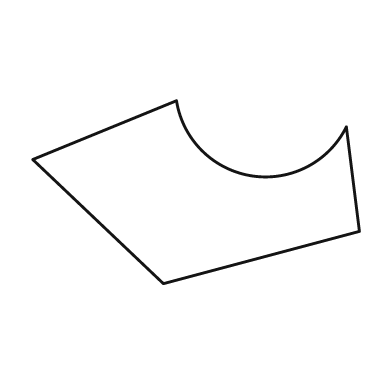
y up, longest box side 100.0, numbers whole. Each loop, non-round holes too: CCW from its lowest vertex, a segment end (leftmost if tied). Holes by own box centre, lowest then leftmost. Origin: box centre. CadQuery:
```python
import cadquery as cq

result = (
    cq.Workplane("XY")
    .moveTo(-10.0, -28.0)
    .lineTo(50.0, -12.0)
    .lineTo(46.0, 20.0)
    .threePointArc((17.0, 5.0), (-6.0, 28.0))
    .lineTo(-50.0, 10.0)
    .close()
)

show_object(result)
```